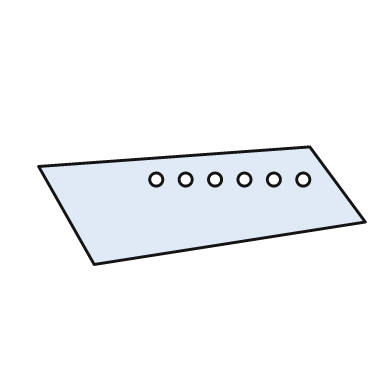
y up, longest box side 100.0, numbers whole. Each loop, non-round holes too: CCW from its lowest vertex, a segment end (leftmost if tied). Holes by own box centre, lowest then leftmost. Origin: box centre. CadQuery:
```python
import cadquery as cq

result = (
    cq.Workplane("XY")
    .moveTo(-33.0, -18.0)
    .lineTo(50.0, -5.0)
    .lineTo(33.0, 18.0)
    .lineTo(-50.0, 12.0)
    .close()
    .moveTo(-14.0, 8.0)
    .circle(2.0)
    .moveTo(-5.0, 8.0)
    .circle(2.0)
    .moveTo(4.0, 8.0)
    .circle(2.0)
    .moveTo(13.0, 8.0)
    .circle(2.0)
    .moveTo(22.0, 8.0)
    .circle(2.0)
    .moveTo(31.0, 8.0)
    .circle(2.0)
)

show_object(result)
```